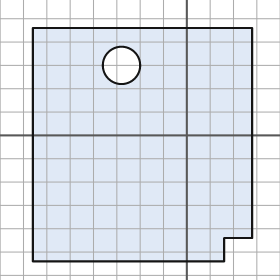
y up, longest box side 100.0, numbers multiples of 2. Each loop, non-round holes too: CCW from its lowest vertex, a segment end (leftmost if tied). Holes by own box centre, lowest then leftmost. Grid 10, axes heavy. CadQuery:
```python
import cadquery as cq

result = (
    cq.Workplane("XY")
    .moveTo(-66.0, -54.0)
    .lineTo(16.0, -54.0)
    .lineTo(16.0, -44.0)
    .lineTo(28.0, -44.0)
    .lineTo(28.0, 46.0)
    .lineTo(-66.0, 46.0)
    .close()
    .moveTo(-28.0, 30.0)
    .circle(8.0)
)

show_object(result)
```